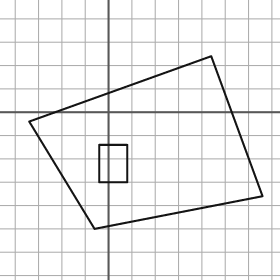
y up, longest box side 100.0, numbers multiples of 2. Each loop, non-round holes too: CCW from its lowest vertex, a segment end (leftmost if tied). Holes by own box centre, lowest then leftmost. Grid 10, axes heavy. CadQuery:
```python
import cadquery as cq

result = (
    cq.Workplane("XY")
    .moveTo(-6.0, -50.0)
    .lineTo(66.0, -36.0)
    .lineTo(44.0, 24.0)
    .lineTo(-34.0, -4.0)
    .close()
    .moveTo(-4.0, -30.0)
    .lineTo(8.0, -30.0)
    .lineTo(8.0, -14.0)
    .lineTo(-4.0, -14.0)
    .close()
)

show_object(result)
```